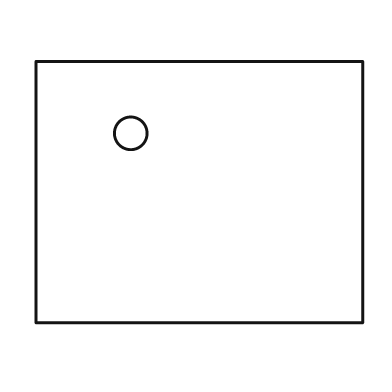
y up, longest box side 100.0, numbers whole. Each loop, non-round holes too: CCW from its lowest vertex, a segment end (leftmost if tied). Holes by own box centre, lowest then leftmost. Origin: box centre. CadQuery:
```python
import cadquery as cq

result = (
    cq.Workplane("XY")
    .moveTo(-50.0, -40.0)
    .lineTo(50.0, -40.0)
    .lineTo(50.0, 40.0)
    .lineTo(-50.0, 40.0)
    .close()
    .moveTo(-21.0, 18.0)
    .circle(5.0)
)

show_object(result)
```